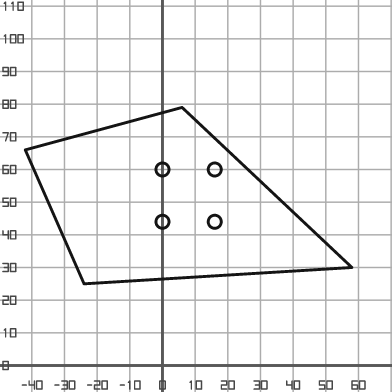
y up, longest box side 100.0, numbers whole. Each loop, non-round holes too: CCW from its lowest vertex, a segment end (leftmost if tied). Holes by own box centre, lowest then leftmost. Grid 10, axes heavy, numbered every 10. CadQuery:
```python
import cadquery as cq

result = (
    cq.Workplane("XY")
    .moveTo(-24.0, 25.0)
    .lineTo(58.0, 30.0)
    .lineTo(6.0, 79.0)
    .lineTo(-42.0, 66.0)
    .close()
    .moveTo(0.0, 44.0)
    .circle(2.0)
    .moveTo(16.0, 44.0)
    .circle(2.0)
    .moveTo(0.0, 60.0)
    .circle(2.0)
    .moveTo(16.0, 60.0)
    .circle(2.0)
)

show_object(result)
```